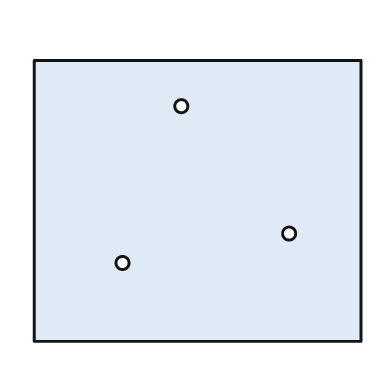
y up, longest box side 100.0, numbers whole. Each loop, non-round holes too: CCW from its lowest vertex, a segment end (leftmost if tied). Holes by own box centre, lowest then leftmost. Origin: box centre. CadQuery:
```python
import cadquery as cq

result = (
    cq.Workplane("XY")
    .moveTo(-50.0, -43.0)
    .lineTo(50.0, -43.0)
    .lineTo(50.0, 43.0)
    .lineTo(-50.0, 43.0)
    .close()
    .moveTo(-23.0, -19.0)
    .circle(2.0)
    .moveTo(28.0, -10.0)
    .circle(2.0)
    .moveTo(-5.0, 29.0)
    .circle(2.0)
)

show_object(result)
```